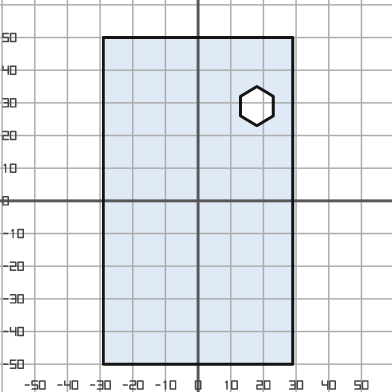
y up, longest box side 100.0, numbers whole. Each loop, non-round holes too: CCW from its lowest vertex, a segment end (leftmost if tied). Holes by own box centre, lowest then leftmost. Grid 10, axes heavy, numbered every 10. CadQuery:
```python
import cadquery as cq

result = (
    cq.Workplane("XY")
    .moveTo(-29.0, -50.0)
    .lineTo(29.0, -50.0)
    .lineTo(29.0, 50.0)
    .lineTo(-29.0, 50.0)
    .close()
    .moveTo(18.0, 23.0)
    .lineTo(23.0, 26.0)
    .lineTo(23.0, 32.0)
    .lineTo(18.0, 35.0)
    .lineTo(13.0, 32.0)
    .lineTo(13.0, 26.0)
    .close()
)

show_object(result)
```